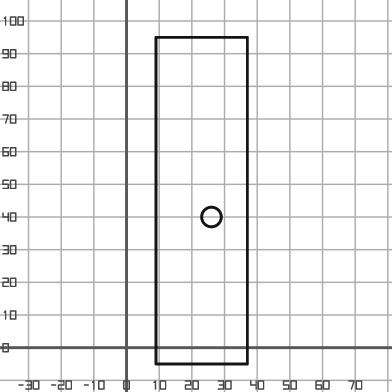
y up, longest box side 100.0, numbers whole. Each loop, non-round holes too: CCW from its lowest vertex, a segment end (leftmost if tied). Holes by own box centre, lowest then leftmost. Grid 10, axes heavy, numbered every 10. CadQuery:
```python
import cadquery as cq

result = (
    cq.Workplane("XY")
    .moveTo(9.0, -5.0)
    .lineTo(37.0, -5.0)
    .lineTo(37.0, 95.0)
    .lineTo(9.0, 95.0)
    .close()
    .moveTo(26.0, 40.0)
    .circle(3.0)
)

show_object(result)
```